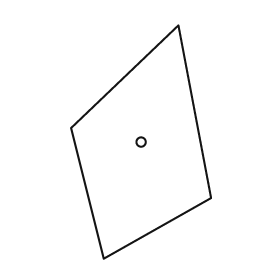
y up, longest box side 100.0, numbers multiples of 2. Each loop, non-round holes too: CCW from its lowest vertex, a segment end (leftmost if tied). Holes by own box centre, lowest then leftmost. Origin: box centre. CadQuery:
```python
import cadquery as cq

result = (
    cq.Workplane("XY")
    .moveTo(-16.0, -50.0)
    .lineTo(30.0, -24.0)
    .lineTo(16.0, 50.0)
    .lineTo(-30.0, 6.0)
    .close()
    .moveTo(0.0, 0.0)
    .circle(2.0)
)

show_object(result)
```